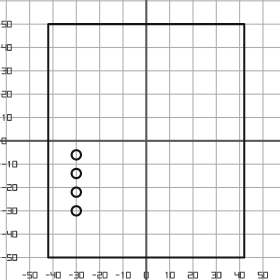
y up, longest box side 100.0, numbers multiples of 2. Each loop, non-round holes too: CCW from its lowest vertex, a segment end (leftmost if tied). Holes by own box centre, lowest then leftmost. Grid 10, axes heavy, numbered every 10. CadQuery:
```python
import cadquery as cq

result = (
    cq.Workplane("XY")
    .moveTo(-42.0, -50.0)
    .lineTo(42.0, -50.0)
    .lineTo(42.0, 50.0)
    .lineTo(-42.0, 50.0)
    .close()
    .moveTo(-30.0, -30.0)
    .circle(2.0)
    .moveTo(-30.0, -22.0)
    .circle(2.0)
    .moveTo(-30.0, -14.0)
    .circle(2.0)
    .moveTo(-30.0, -6.0)
    .circle(2.0)
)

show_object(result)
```